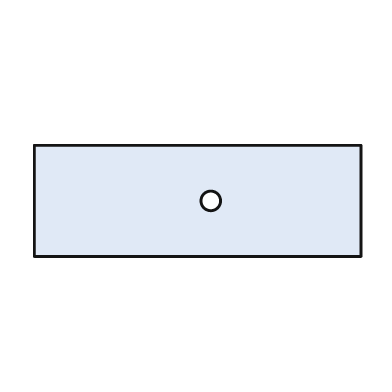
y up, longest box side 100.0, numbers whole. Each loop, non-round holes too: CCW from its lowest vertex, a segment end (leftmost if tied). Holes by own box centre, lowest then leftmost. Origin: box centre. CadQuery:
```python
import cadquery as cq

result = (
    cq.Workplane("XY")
    .moveTo(-50.0, -17.0)
    .lineTo(50.0, -17.0)
    .lineTo(50.0, 17.0)
    .lineTo(-50.0, 17.0)
    .close()
    .moveTo(4.0, 0.0)
    .circle(3.0)
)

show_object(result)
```